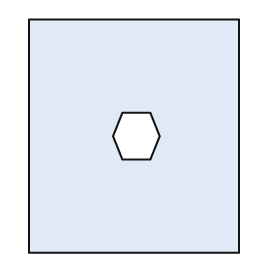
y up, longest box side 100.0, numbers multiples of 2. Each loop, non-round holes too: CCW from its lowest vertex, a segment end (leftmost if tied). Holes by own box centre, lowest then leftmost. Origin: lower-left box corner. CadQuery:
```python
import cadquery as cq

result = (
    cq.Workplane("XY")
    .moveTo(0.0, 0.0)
    .lineTo(90.0, 0.0)
    .lineTo(90.0, 100.0)
    .lineTo(0.0, 100.0)
    .close()
    .moveTo(40.0, 40.0)
    .lineTo(52.0, 40.0)
    .lineTo(56.0, 50.0)
    .lineTo(52.0, 60.0)
    .lineTo(40.0, 60.0)
    .lineTo(36.0, 50.0)
    .close()
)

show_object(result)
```